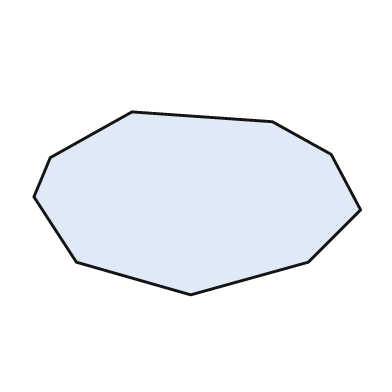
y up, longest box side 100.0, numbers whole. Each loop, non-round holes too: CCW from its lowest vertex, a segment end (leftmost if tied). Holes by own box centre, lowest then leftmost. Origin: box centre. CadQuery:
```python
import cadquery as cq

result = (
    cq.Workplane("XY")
    .moveTo(-2.0, -28.0)
    .lineTo(34.0, -18.0)
    .lineTo(50.0, -2.0)
    .lineTo(41.0, 15.0)
    .lineTo(23.0, 25.0)
    .lineTo(-20.0, 28.0)
    .lineTo(-45.0, 14.0)
    .lineTo(-50.0, 2.0)
    .lineTo(-37.0, -18.0)
    .close()
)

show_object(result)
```